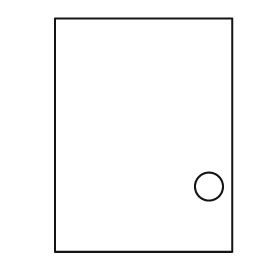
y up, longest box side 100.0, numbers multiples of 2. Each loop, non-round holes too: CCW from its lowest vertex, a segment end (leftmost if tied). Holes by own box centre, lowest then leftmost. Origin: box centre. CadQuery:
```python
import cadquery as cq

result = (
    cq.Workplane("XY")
    .moveTo(-38.0, -50.0)
    .lineTo(38.0, -50.0)
    .lineTo(38.0, 50.0)
    .lineTo(-38.0, 50.0)
    .close()
    .moveTo(28.0, -22.0)
    .circle(6.0)
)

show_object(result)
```